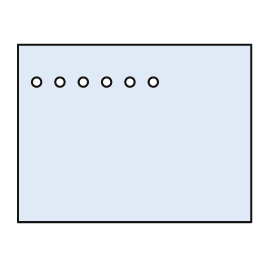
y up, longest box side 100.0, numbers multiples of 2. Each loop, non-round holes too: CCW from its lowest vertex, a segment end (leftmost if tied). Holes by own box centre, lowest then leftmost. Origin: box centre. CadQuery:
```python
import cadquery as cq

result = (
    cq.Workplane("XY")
    .moveTo(-50.0, -38.0)
    .lineTo(50.0, -38.0)
    .lineTo(50.0, 38.0)
    .lineTo(-50.0, 38.0)
    .close()
    .moveTo(-42.0, 22.0)
    .circle(2.0)
    .moveTo(-32.0, 22.0)
    .circle(2.0)
    .moveTo(-22.0, 22.0)
    .circle(2.0)
    .moveTo(-12.0, 22.0)
    .circle(2.0)
    .moveTo(-2.0, 22.0)
    .circle(2.0)
    .moveTo(8.0, 22.0)
    .circle(2.0)
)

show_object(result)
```